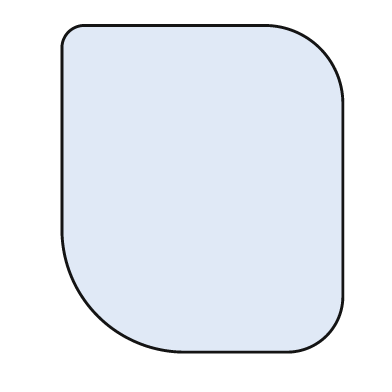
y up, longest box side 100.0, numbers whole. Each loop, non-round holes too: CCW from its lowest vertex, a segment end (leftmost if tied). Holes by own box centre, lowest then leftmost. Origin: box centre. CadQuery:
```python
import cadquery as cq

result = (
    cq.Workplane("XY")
    .moveTo(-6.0, -50.0)
    .lineTo(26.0, -50.0)
    .threePointArc((38.0, -45.0), (43.0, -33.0))
    .lineTo(43.0, 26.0)
    .threePointArc((36.0, 43.0), (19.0, 50.0))
    .lineTo(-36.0, 50.0)
    .threePointArc((-41.0, 48.0), (-43.0, 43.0))
    .lineTo(-43.0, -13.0)
    .threePointArc((-32.0, -39.0), (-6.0, -50.0))
    .close()
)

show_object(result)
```